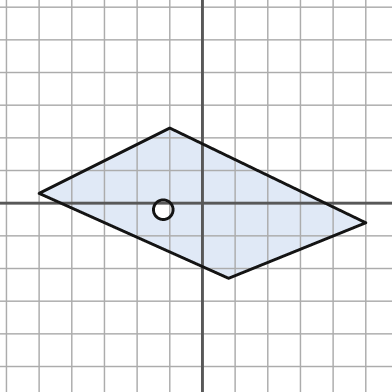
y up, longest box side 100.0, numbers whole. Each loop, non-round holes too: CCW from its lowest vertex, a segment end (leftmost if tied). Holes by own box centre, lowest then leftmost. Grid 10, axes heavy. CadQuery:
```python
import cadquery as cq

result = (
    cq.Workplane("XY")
    .moveTo(8.0, -23.0)
    .lineTo(50.0, -6.0)
    .lineTo(-10.0, 23.0)
    .lineTo(-50.0, 3.0)
    .close()
    .moveTo(-12.0, -2.0)
    .circle(3.0)
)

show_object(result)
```